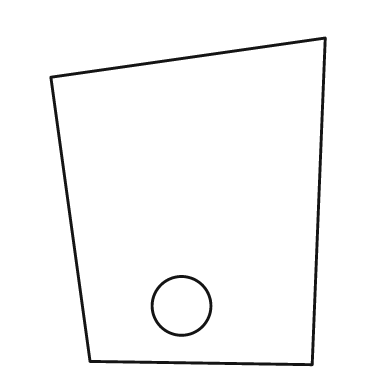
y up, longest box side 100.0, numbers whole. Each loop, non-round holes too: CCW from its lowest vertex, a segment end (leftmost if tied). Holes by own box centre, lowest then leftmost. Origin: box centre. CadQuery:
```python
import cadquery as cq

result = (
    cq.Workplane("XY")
    .moveTo(38.0, -50.0)
    .lineTo(42.0, 50.0)
    .lineTo(-42.0, 38.0)
    .lineTo(-30.0, -49.0)
    .close()
    .moveTo(-2.0, -32.0)
    .circle(9.0)
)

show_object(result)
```